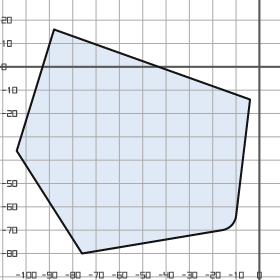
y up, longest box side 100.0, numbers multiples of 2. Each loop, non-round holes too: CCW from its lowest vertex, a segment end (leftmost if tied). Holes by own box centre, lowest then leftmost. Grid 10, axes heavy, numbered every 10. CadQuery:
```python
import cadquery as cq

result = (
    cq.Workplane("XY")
    .moveTo(-76.0, -80.0)
    .lineTo(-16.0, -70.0)
    .threePointArc((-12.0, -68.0), (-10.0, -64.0))
    .lineTo(-4.0, -14.0)
    .lineTo(-88.0, 16.0)
    .lineTo(-104.0, -36.0)
    .close()
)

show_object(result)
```